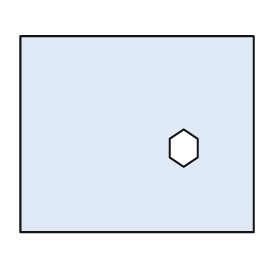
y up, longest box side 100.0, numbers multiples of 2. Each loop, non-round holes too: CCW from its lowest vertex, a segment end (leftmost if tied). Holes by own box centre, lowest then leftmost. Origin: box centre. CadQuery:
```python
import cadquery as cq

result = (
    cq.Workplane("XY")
    .moveTo(-50.0, -42.0)
    .lineTo(50.0, -42.0)
    .lineTo(50.0, 42.0)
    .lineTo(-50.0, 42.0)
    .close()
    .moveTo(20.0, -14.0)
    .lineTo(26.0, -10.0)
    .lineTo(26.0, -2.0)
    .lineTo(20.0, 2.0)
    .lineTo(14.0, -2.0)
    .lineTo(14.0, -10.0)
    .close()
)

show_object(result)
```